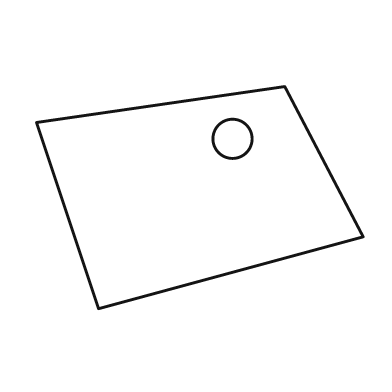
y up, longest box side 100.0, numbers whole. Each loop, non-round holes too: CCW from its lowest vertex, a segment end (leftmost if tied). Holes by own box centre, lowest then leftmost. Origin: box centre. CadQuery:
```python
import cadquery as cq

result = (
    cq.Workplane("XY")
    .moveTo(-31.0, -34.0)
    .lineTo(50.0, -12.0)
    .lineTo(26.0, 34.0)
    .lineTo(-50.0, 23.0)
    .close()
    .moveTo(10.0, 18.0)
    .circle(6.0)
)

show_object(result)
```